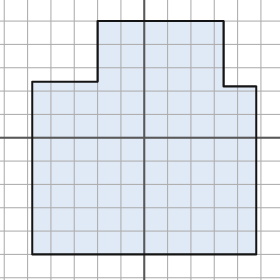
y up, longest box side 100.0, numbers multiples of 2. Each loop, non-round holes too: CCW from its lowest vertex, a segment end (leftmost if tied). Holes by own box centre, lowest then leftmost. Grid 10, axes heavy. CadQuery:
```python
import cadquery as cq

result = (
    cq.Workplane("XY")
    .moveTo(-48.0, -50.0)
    .lineTo(48.0, -50.0)
    .lineTo(48.0, 22.0)
    .lineTo(34.0, 22.0)
    .lineTo(34.0, 50.0)
    .lineTo(-20.0, 50.0)
    .lineTo(-20.0, 24.0)
    .lineTo(-48.0, 24.0)
    .close()
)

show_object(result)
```